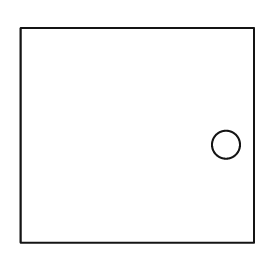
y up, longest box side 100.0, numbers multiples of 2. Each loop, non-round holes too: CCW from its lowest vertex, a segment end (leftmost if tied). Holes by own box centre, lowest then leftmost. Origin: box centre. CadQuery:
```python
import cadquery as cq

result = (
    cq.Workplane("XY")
    .moveTo(-50.0, -46.0)
    .lineTo(50.0, -46.0)
    .lineTo(50.0, 46.0)
    .lineTo(-50.0, 46.0)
    .close()
    .moveTo(38.0, -4.0)
    .circle(6.0)
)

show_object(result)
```